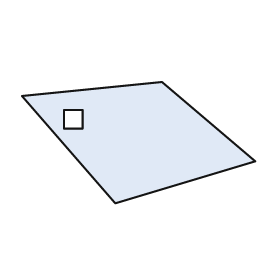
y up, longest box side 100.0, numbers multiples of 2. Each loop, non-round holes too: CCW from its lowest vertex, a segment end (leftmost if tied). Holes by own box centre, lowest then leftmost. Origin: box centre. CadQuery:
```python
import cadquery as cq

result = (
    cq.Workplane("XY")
    .moveTo(-10.0, -26.0)
    .lineTo(50.0, -8.0)
    .lineTo(10.0, 26.0)
    .lineTo(-50.0, 20.0)
    .close()
    .moveTo(-32.0, 6.0)
    .lineTo(-24.0, 6.0)
    .lineTo(-24.0, 14.0)
    .lineTo(-32.0, 14.0)
    .close()
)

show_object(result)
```